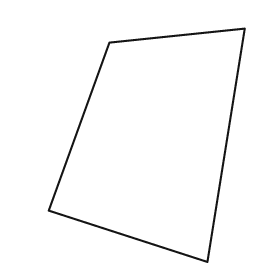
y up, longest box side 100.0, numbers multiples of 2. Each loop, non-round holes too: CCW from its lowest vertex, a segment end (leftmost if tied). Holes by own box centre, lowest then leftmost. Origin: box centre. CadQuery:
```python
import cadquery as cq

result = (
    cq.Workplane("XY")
    .moveTo(26.0, -50.0)
    .lineTo(42.0, 50.0)
    .lineTo(-16.0, 44.0)
    .lineTo(-42.0, -28.0)
    .close()
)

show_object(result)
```